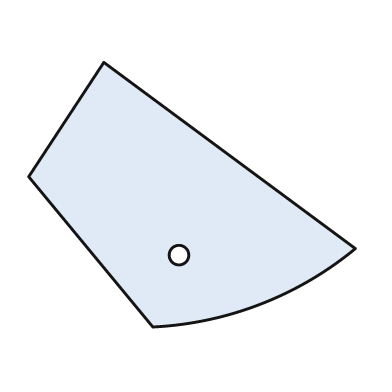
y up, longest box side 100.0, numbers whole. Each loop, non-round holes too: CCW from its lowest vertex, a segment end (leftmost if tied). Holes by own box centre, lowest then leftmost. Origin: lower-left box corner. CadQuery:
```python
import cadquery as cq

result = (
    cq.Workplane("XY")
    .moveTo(38.0, 0.0)
    .threePointArc((71.0, 7.0), (100.0, 24.0))
    .lineTo(23.0, 81.0)
    .lineTo(0.0, 46.0)
    .close()
    .moveTo(46.0, 22.0)
    .circle(3.0)
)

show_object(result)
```